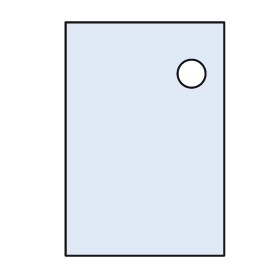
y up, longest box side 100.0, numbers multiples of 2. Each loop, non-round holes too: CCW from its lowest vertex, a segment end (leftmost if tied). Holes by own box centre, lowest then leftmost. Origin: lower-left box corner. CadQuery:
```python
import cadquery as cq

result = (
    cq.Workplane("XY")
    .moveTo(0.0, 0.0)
    .lineTo(68.0, 0.0)
    .lineTo(68.0, 100.0)
    .lineTo(0.0, 100.0)
    .close()
    .moveTo(54.0, 78.0)
    .circle(6.0)
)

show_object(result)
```